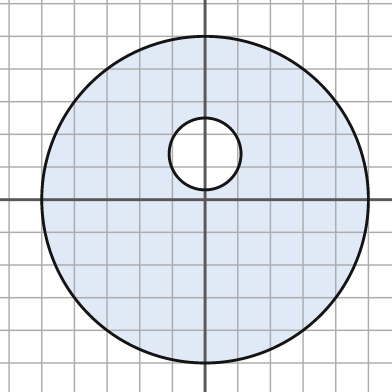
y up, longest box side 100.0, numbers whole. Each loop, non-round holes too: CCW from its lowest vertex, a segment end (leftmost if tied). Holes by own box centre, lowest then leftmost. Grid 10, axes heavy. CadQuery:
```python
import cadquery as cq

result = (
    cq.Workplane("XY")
    .moveTo(0.0, 0.0)
    .circle(50.0)
    .moveTo(0.0, 14.0)
    .circle(11.0)
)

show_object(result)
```